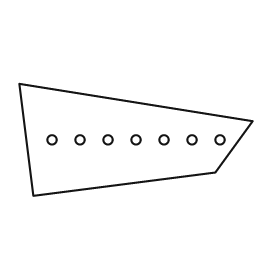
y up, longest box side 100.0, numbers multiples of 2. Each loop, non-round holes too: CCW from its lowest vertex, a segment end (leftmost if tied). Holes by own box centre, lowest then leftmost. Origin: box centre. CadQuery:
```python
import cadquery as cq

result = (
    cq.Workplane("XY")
    .moveTo(-44.0, -24.0)
    .lineTo(34.0, -14.0)
    .lineTo(50.0, 8.0)
    .lineTo(-50.0, 24.0)
    .close()
    .moveTo(-36.0, 0.0)
    .circle(2.0)
    .moveTo(-24.0, 0.0)
    .circle(2.0)
    .moveTo(-12.0, 0.0)
    .circle(2.0)
    .moveTo(0.0, 0.0)
    .circle(2.0)
    .moveTo(12.0, 0.0)
    .circle(2.0)
    .moveTo(24.0, 0.0)
    .circle(2.0)
    .moveTo(36.0, 0.0)
    .circle(2.0)
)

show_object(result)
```